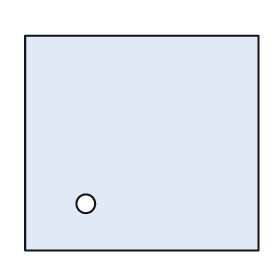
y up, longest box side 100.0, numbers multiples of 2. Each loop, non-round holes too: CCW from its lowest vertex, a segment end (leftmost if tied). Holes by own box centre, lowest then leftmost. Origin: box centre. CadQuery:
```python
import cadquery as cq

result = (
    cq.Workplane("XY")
    .moveTo(-50.0, -46.0)
    .lineTo(50.0, -46.0)
    .lineTo(50.0, 46.0)
    .lineTo(-50.0, 46.0)
    .close()
    .moveTo(-24.0, -26.0)
    .circle(4.0)
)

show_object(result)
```